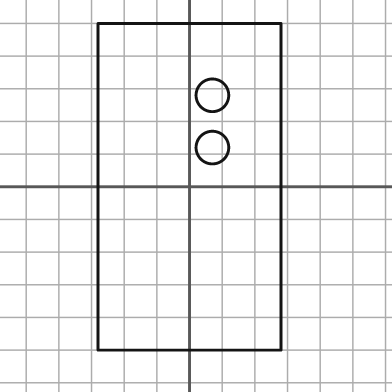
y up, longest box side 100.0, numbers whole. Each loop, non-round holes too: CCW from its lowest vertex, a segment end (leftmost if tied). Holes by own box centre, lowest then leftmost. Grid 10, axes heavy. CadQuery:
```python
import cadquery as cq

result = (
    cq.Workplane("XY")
    .moveTo(-28.0, -50.0)
    .lineTo(28.0, -50.0)
    .lineTo(28.0, 50.0)
    .lineTo(-28.0, 50.0)
    .close()
    .moveTo(7.0, 12.0)
    .circle(5.0)
    .moveTo(7.0, 28.0)
    .circle(5.0)
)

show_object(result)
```